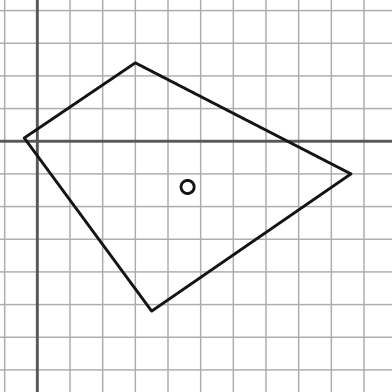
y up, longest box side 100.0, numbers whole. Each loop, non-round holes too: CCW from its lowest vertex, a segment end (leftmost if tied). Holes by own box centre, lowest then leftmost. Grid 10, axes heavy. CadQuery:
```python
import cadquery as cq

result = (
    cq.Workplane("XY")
    .moveTo(35.0, -52.0)
    .lineTo(96.0, -10.0)
    .lineTo(30.0, 24.0)
    .lineTo(-4.0, 1.0)
    .close()
    .moveTo(46.0, -14.0)
    .circle(2.0)
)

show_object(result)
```